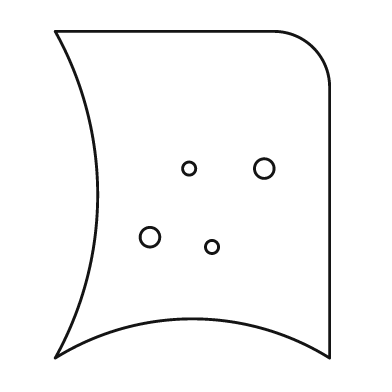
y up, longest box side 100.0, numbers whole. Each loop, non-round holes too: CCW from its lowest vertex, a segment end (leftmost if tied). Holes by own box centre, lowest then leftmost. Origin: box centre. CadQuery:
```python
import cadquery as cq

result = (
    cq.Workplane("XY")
    .moveTo(-42.0, -50.0)
    .threePointArc((0.0, -38.0), (42.0, -50.0))
    .lineTo(42.0, 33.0)
    .threePointArc((37.0, 45.0), (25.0, 50.0))
    .lineTo(-42.0, 50.0)
    .threePointArc((-29.0, 0.0), (-42.0, -50.0))
    .close()
    .moveTo(6.0, -16.0)
    .circle(2.0)
    .moveTo(-13.0, -13.0)
    .circle(3.0)
    .moveTo(-1.0, 8.0)
    .circle(2.0)
    .moveTo(22.0, 8.0)
    .circle(3.0)
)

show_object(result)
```